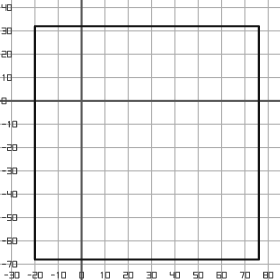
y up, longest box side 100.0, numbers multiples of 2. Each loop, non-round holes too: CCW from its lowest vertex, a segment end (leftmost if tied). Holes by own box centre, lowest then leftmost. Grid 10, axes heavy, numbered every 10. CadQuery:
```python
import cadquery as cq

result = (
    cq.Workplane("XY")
    .moveTo(-20.0, -68.0)
    .lineTo(76.0, -68.0)
    .lineTo(76.0, 32.0)
    .lineTo(-20.0, 32.0)
    .close()
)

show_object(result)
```